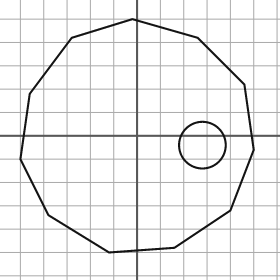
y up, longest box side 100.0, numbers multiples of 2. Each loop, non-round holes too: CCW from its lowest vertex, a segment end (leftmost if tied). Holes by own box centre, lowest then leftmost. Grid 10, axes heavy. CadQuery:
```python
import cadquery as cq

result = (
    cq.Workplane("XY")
    .moveTo(-12.0, -50.0)
    .lineTo(16.0, -48.0)
    .lineTo(40.0, -32.0)
    .lineTo(50.0, -6.0)
    .lineTo(46.0, 22.0)
    .lineTo(26.0, 42.0)
    .lineTo(-2.0, 50.0)
    .lineTo(-28.0, 42.0)
    .lineTo(-46.0, 18.0)
    .lineTo(-50.0, -10.0)
    .lineTo(-38.0, -34.0)
    .close()
    .moveTo(28.0, -4.0)
    .circle(10.0)
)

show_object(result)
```